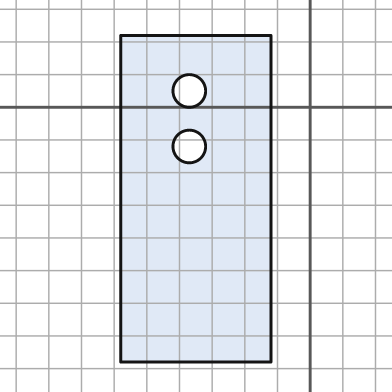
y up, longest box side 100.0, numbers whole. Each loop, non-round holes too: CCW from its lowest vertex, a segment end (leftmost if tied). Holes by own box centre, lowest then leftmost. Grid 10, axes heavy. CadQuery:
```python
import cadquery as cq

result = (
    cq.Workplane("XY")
    .moveTo(-58.0, -78.0)
    .lineTo(-12.0, -78.0)
    .lineTo(-12.0, 22.0)
    .lineTo(-58.0, 22.0)
    .close()
    .moveTo(-37.0, -12.0)
    .circle(5.0)
    .moveTo(-37.0, 5.0)
    .circle(5.0)
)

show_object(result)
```